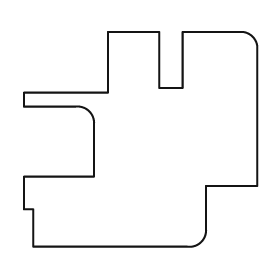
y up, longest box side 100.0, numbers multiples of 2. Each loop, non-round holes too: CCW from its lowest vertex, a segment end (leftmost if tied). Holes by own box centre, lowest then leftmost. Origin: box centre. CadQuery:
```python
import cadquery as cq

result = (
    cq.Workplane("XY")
    .moveTo(-46.0, -46.0)
    .lineTo(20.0, -46.0)
    .threePointArc((26.0, -44.0), (28.0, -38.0))
    .lineTo(28.0, -20.0)
    .lineTo(50.0, -20.0)
    .lineTo(50.0, 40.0)
    .threePointArc((48.0, 44.0), (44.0, 46.0))
    .lineTo(18.0, 46.0)
    .lineTo(18.0, 22.0)
    .lineTo(8.0, 22.0)
    .lineTo(8.0, 46.0)
    .lineTo(-14.0, 46.0)
    .lineTo(-14.0, 20.0)
    .lineTo(-50.0, 20.0)
    .lineTo(-50.0, 14.0)
    .lineTo(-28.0, 14.0)
    .threePointArc((-22.0, 12.0), (-20.0, 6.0))
    .lineTo(-20.0, -16.0)
    .lineTo(-50.0, -16.0)
    .lineTo(-50.0, -30.0)
    .lineTo(-46.0, -30.0)
    .close()
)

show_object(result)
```